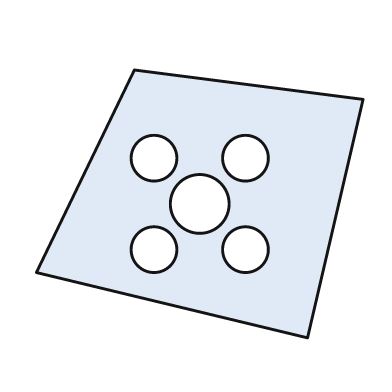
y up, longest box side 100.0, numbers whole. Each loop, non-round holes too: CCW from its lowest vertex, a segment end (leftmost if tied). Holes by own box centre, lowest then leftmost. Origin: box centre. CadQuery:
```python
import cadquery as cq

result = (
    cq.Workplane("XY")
    .moveTo(33.0, -41.0)
    .lineTo(50.0, 32.0)
    .lineTo(-20.0, 41.0)
    .lineTo(-50.0, -21.0)
    .close()
    .moveTo(-14.0, -14.0)
    .circle(7.0)
    .moveTo(14.0, -14.0)
    .circle(7.0)
    .moveTo(0.0, 0.0)
    .circle(9.0)
    .moveTo(-14.0, 14.0)
    .circle(7.0)
    .moveTo(14.0, 14.0)
    .circle(7.0)
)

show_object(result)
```